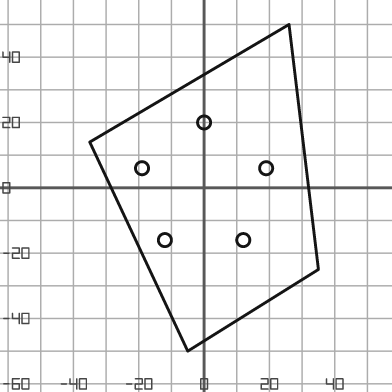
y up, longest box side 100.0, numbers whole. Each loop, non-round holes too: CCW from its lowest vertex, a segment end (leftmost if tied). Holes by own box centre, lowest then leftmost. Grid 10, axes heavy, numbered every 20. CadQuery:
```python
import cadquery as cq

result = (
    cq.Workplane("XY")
    .moveTo(-5.0, -50.0)
    .lineTo(35.0, -25.0)
    .lineTo(26.0, 50.0)
    .lineTo(-35.0, 14.0)
    .close()
    .moveTo(-12.0, -16.0)
    .circle(2.0)
    .moveTo(12.0, -16.0)
    .circle(2.0)
    .moveTo(-19.0, 6.0)
    .circle(2.0)
    .moveTo(19.0, 6.0)
    .circle(2.0)
    .moveTo(0.0, 20.0)
    .circle(2.0)
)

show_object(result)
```